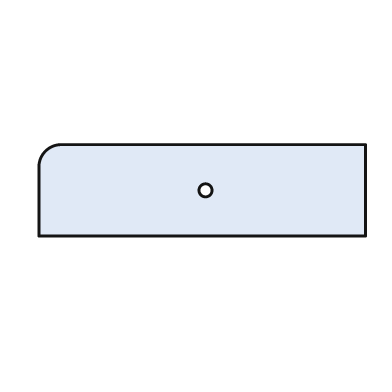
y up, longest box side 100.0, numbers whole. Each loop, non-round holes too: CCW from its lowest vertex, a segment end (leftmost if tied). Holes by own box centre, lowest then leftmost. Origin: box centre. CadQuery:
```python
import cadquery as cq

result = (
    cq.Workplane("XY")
    .moveTo(-50.0, -14.0)
    .lineTo(50.0, -14.0)
    .lineTo(50.0, 14.0)
    .lineTo(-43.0, 14.0)
    .threePointArc((-48.0, 12.0), (-50.0, 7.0))
    .close()
    .moveTo(1.0, 0.0)
    .circle(2.0)
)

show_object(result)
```